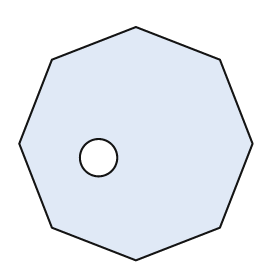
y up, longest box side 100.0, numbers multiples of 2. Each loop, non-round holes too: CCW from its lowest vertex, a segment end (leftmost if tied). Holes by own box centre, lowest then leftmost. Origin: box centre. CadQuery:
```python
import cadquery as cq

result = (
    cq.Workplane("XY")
    .moveTo(0.0, -50.0)
    .lineTo(36.0, -36.0)
    .lineTo(50.0, 0.0)
    .lineTo(36.0, 36.0)
    .lineTo(0.0, 50.0)
    .lineTo(-36.0, 36.0)
    .lineTo(-50.0, 0.0)
    .lineTo(-36.0, -36.0)
    .close()
    .moveTo(-16.0, -6.0)
    .circle(8.0)
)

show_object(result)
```